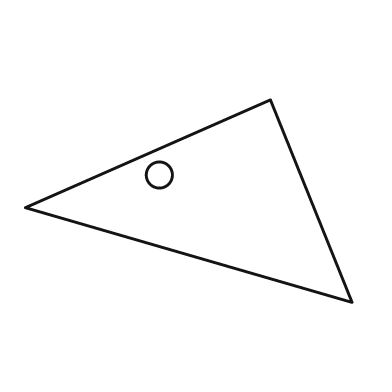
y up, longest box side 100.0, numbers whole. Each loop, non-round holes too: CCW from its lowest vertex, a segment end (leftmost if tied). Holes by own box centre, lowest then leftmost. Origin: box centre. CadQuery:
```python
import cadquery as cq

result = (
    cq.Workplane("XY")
    .moveTo(50.0, -31.0)
    .lineTo(25.0, 31.0)
    .lineTo(-50.0, -2.0)
    .close()
    .moveTo(-9.0, 8.0)
    .circle(4.0)
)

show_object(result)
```